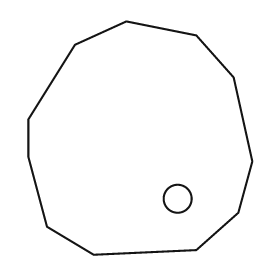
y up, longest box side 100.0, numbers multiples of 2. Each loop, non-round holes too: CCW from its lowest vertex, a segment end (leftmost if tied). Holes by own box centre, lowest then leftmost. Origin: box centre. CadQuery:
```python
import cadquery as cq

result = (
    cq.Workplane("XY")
    .moveTo(-20.0, -50.0)
    .lineTo(24.0, -48.0)
    .lineTo(42.0, -32.0)
    .lineTo(48.0, -10.0)
    .lineTo(40.0, 26.0)
    .lineTo(24.0, 44.0)
    .lineTo(-6.0, 50.0)
    .lineTo(-28.0, 40.0)
    .lineTo(-48.0, 8.0)
    .lineTo(-48.0, -8.0)
    .lineTo(-40.0, -38.0)
    .close()
    .moveTo(16.0, -26.0)
    .circle(6.0)
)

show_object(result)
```